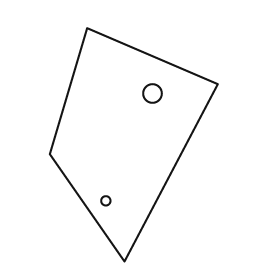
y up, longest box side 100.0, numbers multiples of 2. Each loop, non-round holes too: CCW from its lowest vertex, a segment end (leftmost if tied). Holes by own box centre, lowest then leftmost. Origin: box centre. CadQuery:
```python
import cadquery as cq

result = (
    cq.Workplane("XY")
    .moveTo(-4.0, -50.0)
    .lineTo(36.0, 26.0)
    .lineTo(-20.0, 50.0)
    .lineTo(-36.0, -4.0)
    .close()
    .moveTo(-12.0, -24.0)
    .circle(2.0)
    .moveTo(8.0, 22.0)
    .circle(4.0)
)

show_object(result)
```